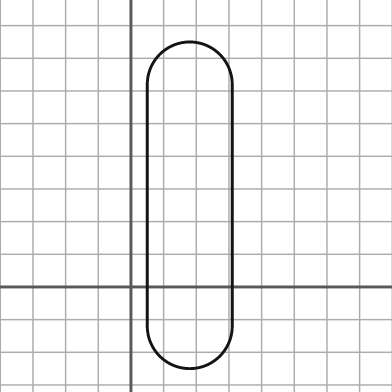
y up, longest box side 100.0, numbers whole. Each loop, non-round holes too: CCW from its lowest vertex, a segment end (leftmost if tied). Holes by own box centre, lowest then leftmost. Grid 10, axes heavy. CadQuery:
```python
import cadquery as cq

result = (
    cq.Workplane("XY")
    .moveTo(5.0, -12.0)
    .threePointArc((18.0, -25.0), (31.0, -12.0))
    .lineTo(31.0, 62.0)
    .threePointArc((18.0, 75.0), (5.0, 62.0))
    .close()
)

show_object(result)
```